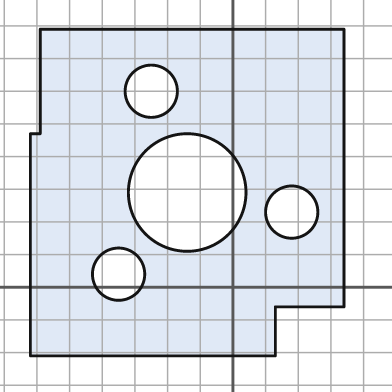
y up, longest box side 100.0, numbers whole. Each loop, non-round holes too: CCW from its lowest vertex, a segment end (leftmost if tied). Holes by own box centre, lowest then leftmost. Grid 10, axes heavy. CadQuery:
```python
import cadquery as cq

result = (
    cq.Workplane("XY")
    .moveTo(-62.0, -21.0)
    .lineTo(13.0, -21.0)
    .lineTo(13.0, -6.0)
    .lineTo(34.0, -6.0)
    .lineTo(34.0, 79.0)
    .lineTo(-59.0, 79.0)
    .lineTo(-59.0, 47.0)
    .lineTo(-62.0, 47.0)
    .close()
    .moveTo(-35.0, 4.0)
    .circle(8.0)
    .moveTo(18.0, 23.0)
    .circle(8.0)
    .moveTo(-14.0, 29.0)
    .circle(18.0)
    .moveTo(-25.0, 60.0)
    .circle(8.0)
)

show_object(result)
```